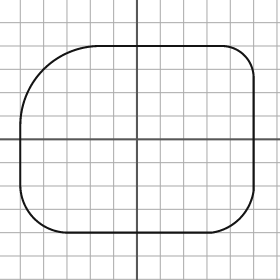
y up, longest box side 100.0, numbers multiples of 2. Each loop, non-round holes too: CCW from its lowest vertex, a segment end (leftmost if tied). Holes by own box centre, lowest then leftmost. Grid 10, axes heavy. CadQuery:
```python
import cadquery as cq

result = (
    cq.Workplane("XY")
    .moveTo(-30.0, -40.0)
    .lineTo(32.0, -40.0)
    .threePointArc((44.0, -34.0), (50.0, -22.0))
    .lineTo(50.0, 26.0)
    .threePointArc((46.0, 36.0), (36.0, 40.0))
    .lineTo(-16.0, 40.0)
    .threePointArc((-40.0, 30.0), (-50.0, 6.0))
    .lineTo(-50.0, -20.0)
    .threePointArc((-44.0, -34.0), (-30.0, -40.0))
    .close()
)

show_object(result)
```